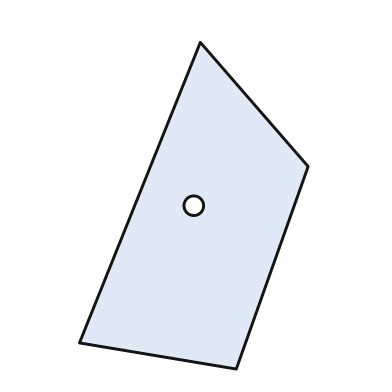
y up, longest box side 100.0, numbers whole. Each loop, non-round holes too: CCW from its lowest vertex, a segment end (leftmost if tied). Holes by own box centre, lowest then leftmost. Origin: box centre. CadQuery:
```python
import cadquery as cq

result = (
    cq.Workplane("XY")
    .moveTo(13.0, -50.0)
    .lineTo(35.0, 12.0)
    .lineTo(2.0, 50.0)
    .lineTo(-35.0, -42.0)
    .close()
    .moveTo(0.0, 0.0)
    .circle(3.0)
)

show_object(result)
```